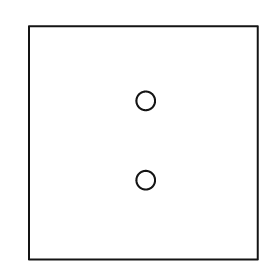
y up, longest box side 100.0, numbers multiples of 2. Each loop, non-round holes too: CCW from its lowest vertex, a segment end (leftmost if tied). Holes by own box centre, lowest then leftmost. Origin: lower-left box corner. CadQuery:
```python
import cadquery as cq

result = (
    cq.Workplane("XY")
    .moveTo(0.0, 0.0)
    .lineTo(98.0, 0.0)
    .lineTo(98.0, 100.0)
    .lineTo(0.0, 100.0)
    .close()
    .moveTo(50.0, 34.0)
    .circle(4.0)
    .moveTo(50.0, 68.0)
    .circle(4.0)
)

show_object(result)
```